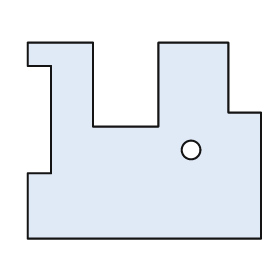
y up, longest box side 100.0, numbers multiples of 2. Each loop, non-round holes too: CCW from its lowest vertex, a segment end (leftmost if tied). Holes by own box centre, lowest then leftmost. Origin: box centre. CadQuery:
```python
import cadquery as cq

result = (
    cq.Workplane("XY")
    .moveTo(-50.0, -42.0)
    .lineTo(50.0, -42.0)
    .lineTo(50.0, 12.0)
    .lineTo(36.0, 12.0)
    .lineTo(36.0, 42.0)
    .lineTo(6.0, 42.0)
    .lineTo(6.0, 6.0)
    .lineTo(-22.0, 6.0)
    .lineTo(-22.0, 42.0)
    .lineTo(-50.0, 42.0)
    .lineTo(-50.0, 32.0)
    .lineTo(-40.0, 32.0)
    .lineTo(-40.0, -14.0)
    .lineTo(-50.0, -14.0)
    .close()
    .moveTo(20.0, -4.0)
    .circle(4.0)
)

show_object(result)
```